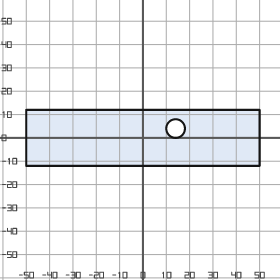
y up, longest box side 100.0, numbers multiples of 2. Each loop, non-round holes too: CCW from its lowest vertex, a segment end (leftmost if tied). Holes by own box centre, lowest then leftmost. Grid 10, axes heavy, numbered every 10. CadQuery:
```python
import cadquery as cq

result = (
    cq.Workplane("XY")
    .moveTo(-50.0, -12.0)
    .lineTo(50.0, -12.0)
    .lineTo(50.0, 12.0)
    .lineTo(-50.0, 12.0)
    .close()
    .moveTo(14.0, 4.0)
    .circle(4.0)
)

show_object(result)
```